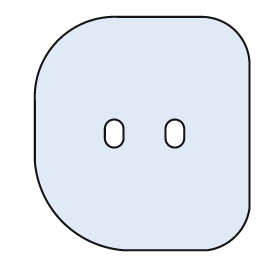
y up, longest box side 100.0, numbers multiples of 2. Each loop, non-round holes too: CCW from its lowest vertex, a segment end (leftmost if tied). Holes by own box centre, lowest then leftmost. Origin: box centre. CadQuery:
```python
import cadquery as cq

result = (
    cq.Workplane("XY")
    .moveTo(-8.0, -50.0)
    .lineTo(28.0, -50.0)
    .threePointArc((40.0, -44.0), (46.0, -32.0))
    .lineTo(46.0, 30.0)
    .threePointArc((40.0, 44.0), (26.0, 50.0))
    .lineTo(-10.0, 50.0)
    .threePointArc((-36.0, 40.0), (-46.0, 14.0))
    .lineTo(-46.0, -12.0)
    .threePointArc((-34.0, -38.0), (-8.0, -50.0))
    .close()
    .moveTo(-16.0, -2.0)
    .threePointArc((-12.0, -6.0), (-8.0, -2.0))
    .lineTo(-8.0, 2.0)
    .threePointArc((-12.0, 6.0), (-16.0, 2.0))
    .close()
    .moveTo(10.0, -2.0)
    .threePointArc((14.0, -6.0), (18.0, -2.0))
    .lineTo(18.0, 2.0)
    .threePointArc((14.0, 6.0), (10.0, 2.0))
    .close()
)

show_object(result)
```